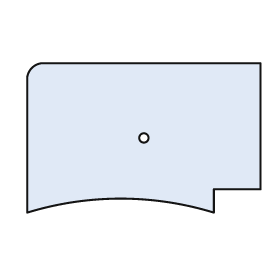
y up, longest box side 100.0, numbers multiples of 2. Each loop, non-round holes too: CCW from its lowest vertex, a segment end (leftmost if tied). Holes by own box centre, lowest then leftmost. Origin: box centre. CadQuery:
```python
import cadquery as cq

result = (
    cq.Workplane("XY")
    .moveTo(-50.0, -32.0)
    .threePointArc((-10.0, -26.0), (30.0, -32.0))
    .lineTo(30.0, -22.0)
    .lineTo(50.0, -22.0)
    .lineTo(50.0, 32.0)
    .lineTo(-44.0, 32.0)
    .threePointArc((-48.0, 30.0), (-50.0, 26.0))
    .close()
    .moveTo(0.0, 0.0)
    .circle(2.0)
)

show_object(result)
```